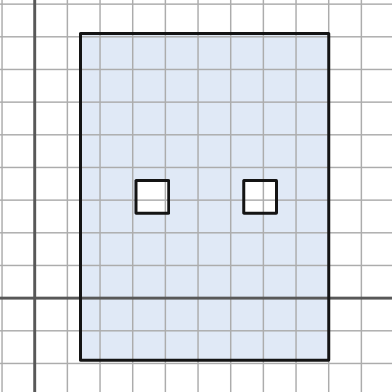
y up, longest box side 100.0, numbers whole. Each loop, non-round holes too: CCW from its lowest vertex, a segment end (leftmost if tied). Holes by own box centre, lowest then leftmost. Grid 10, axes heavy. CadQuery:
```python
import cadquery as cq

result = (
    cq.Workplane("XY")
    .moveTo(14.0, -19.0)
    .lineTo(90.0, -19.0)
    .lineTo(90.0, 81.0)
    .lineTo(14.0, 81.0)
    .close()
    .moveTo(31.0, 26.0)
    .lineTo(41.0, 26.0)
    .lineTo(41.0, 36.0)
    .lineTo(31.0, 36.0)
    .close()
    .moveTo(64.0, 26.0)
    .lineTo(74.0, 26.0)
    .lineTo(74.0, 36.0)
    .lineTo(64.0, 36.0)
    .close()
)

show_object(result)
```